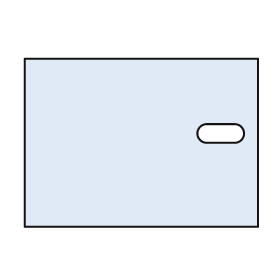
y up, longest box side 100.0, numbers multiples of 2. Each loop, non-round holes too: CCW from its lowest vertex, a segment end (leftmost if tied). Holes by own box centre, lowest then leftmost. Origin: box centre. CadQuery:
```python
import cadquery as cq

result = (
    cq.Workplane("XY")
    .moveTo(-50.0, -36.0)
    .lineTo(50.0, -36.0)
    .lineTo(50.0, 36.0)
    .lineTo(-50.0, 36.0)
    .close()
    .moveTo(28.0, 0.0)
    .lineTo(40.0, 0.0)
    .threePointArc((44.0, 4.0), (40.0, 8.0))
    .lineTo(28.0, 8.0)
    .threePointArc((24.0, 4.0), (28.0, 0.0))
    .close()
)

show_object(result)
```